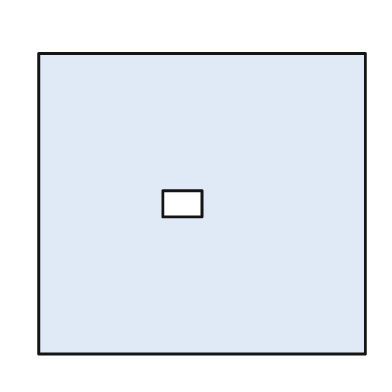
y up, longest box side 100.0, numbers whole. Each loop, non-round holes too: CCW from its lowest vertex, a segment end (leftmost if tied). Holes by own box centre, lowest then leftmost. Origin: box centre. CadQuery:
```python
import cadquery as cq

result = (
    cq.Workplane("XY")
    .moveTo(-50.0, -46.0)
    .lineTo(50.0, -46.0)
    .lineTo(50.0, 46.0)
    .lineTo(-50.0, 46.0)
    .close()
    .moveTo(-12.0, -4.0)
    .lineTo(0.0, -4.0)
    .lineTo(0.0, 4.0)
    .lineTo(-12.0, 4.0)
    .close()
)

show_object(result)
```